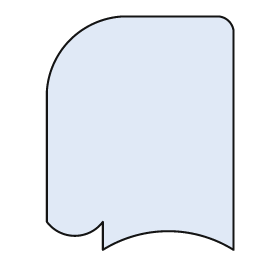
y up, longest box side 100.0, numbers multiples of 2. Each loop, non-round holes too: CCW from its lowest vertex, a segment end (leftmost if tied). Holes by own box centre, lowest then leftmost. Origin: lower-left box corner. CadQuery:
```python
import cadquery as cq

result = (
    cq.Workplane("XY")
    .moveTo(24.0, 0.0)
    .threePointArc((52.0, 8.0), (80.0, 0.0))
    .lineTo(80.0, 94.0)
    .threePointArc((78.0, 98.0), (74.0, 100.0))
    .lineTo(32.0, 100.0)
    .threePointArc((10.0, 90.0), (0.0, 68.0))
    .lineTo(0.0, 12.0)
    .threePointArc((12.0, 6.0), (24.0, 12.0))
    .close()
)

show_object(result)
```